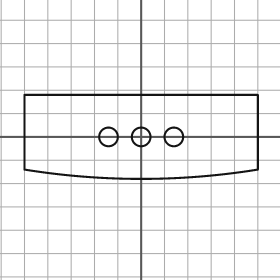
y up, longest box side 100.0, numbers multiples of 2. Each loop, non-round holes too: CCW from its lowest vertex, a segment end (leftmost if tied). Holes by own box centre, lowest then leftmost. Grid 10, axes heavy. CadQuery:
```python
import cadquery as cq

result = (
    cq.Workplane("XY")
    .moveTo(-50.0, -14.0)
    .threePointArc((0.0, -18.0), (50.0, -14.0))
    .lineTo(50.0, 18.0)
    .lineTo(-50.0, 18.0)
    .close()
    .moveTo(-14.0, 0.0)
    .circle(4.0)
    .moveTo(0.0, 0.0)
    .circle(4.0)
    .moveTo(14.0, 0.0)
    .circle(4.0)
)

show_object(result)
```